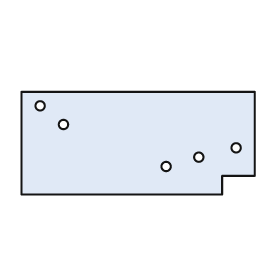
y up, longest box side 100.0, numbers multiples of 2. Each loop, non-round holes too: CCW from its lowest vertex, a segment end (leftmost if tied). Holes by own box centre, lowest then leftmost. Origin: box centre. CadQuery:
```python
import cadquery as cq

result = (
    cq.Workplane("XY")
    .moveTo(-50.0, -22.0)
    .lineTo(36.0, -22.0)
    .lineTo(36.0, -14.0)
    .lineTo(50.0, -14.0)
    .lineTo(50.0, 22.0)
    .lineTo(-50.0, 22.0)
    .close()
    .moveTo(12.0, -10.0)
    .circle(2.0)
    .moveTo(26.0, -6.0)
    .circle(2.0)
    .moveTo(42.0, -2.0)
    .circle(2.0)
    .moveTo(-32.0, 8.0)
    .circle(2.0)
    .moveTo(-42.0, 16.0)
    .circle(2.0)
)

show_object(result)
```